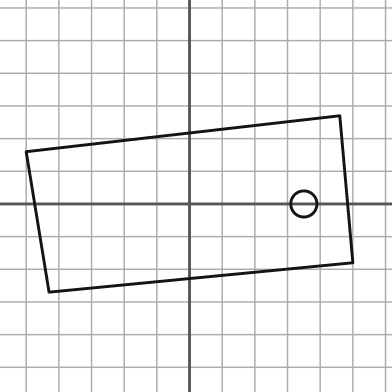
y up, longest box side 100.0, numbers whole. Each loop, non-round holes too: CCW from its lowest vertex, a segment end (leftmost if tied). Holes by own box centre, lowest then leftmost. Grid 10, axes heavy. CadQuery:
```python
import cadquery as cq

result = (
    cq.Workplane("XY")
    .moveTo(-43.0, -27.0)
    .lineTo(50.0, -18.0)
    .lineTo(46.0, 27.0)
    .lineTo(-50.0, 16.0)
    .close()
    .moveTo(35.0, 0.0)
    .circle(4.0)
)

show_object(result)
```